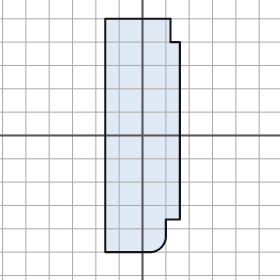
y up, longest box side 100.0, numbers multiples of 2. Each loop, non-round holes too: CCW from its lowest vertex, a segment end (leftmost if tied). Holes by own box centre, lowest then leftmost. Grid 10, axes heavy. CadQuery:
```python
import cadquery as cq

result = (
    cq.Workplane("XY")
    .moveTo(-16.0, -50.0)
    .lineTo(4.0, -50.0)
    .threePointArc((8.0, -48.0), (10.0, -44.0))
    .lineTo(10.0, -36.0)
    .lineTo(16.0, -36.0)
    .lineTo(16.0, 40.0)
    .lineTo(12.0, 40.0)
    .lineTo(12.0, 50.0)
    .lineTo(-16.0, 50.0)
    .close()
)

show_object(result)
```